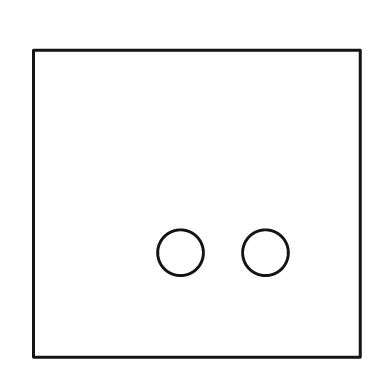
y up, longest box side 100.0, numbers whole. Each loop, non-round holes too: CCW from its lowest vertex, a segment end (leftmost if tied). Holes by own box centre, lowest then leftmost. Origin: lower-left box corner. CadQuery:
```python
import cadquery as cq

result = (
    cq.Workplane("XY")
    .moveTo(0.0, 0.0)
    .lineTo(100.0, 0.0)
    .lineTo(100.0, 94.0)
    .lineTo(0.0, 94.0)
    .close()
    .moveTo(45.0, 32.0)
    .circle(7.0)
    .moveTo(71.0, 32.0)
    .circle(7.0)
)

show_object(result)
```